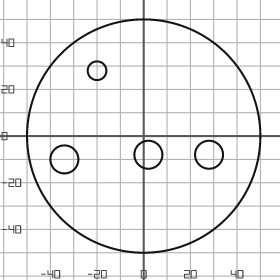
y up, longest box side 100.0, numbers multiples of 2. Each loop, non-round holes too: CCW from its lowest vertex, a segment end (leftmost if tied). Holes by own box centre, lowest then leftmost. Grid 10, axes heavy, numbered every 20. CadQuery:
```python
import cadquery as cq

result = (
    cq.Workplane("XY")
    .moveTo(0.0, 0.0)
    .circle(50.0)
    .moveTo(-34.0, -10.0)
    .circle(6.0)
    .moveTo(2.0, -8.0)
    .circle(6.0)
    .moveTo(28.0, -8.0)
    .circle(6.0)
    .moveTo(-20.0, 28.0)
    .circle(4.0)
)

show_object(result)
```